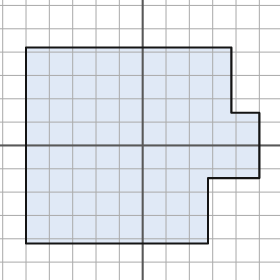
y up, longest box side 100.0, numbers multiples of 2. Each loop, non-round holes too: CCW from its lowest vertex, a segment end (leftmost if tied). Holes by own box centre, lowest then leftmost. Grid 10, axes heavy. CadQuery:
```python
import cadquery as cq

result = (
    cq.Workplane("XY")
    .moveTo(-50.0, -42.0)
    .lineTo(28.0, -42.0)
    .lineTo(28.0, -14.0)
    .lineTo(50.0, -14.0)
    .lineTo(50.0, 14.0)
    .lineTo(38.0, 14.0)
    .lineTo(38.0, 42.0)
    .lineTo(-50.0, 42.0)
    .close()
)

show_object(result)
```